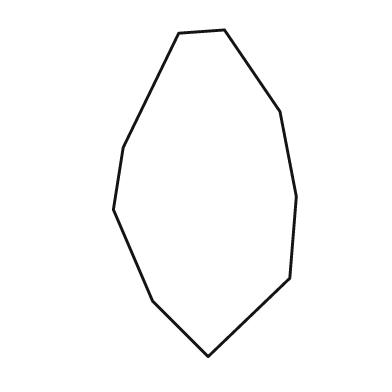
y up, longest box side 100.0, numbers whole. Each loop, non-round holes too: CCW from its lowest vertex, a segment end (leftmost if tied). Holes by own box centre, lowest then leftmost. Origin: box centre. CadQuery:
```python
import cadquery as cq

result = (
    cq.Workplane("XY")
    .moveTo(1.0, -50.0)
    .lineTo(26.0, -26.0)
    .lineTo(28.0, -1.0)
    .lineTo(23.0, 25.0)
    .lineTo(6.0, 50.0)
    .lineTo(-8.0, 49.0)
    .lineTo(-25.0, 14.0)
    .lineTo(-28.0, -5.0)
    .lineTo(-16.0, -33.0)
    .close()
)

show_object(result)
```